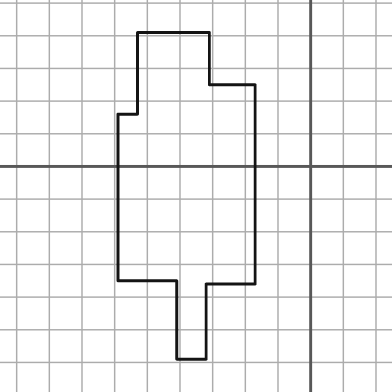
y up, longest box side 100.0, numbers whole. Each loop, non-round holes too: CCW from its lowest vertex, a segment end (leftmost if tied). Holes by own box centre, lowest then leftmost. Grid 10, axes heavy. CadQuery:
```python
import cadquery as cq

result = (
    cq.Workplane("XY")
    .moveTo(-41.0, -59.0)
    .lineTo(-32.0, -59.0)
    .lineTo(-32.0, -36.0)
    .lineTo(-17.0, -36.0)
    .lineTo(-17.0, 25.0)
    .lineTo(-31.0, 25.0)
    .lineTo(-31.0, 41.0)
    .lineTo(-53.0, 41.0)
    .lineTo(-53.0, 16.0)
    .lineTo(-59.0, 16.0)
    .lineTo(-59.0, -35.0)
    .lineTo(-41.0, -35.0)
    .close()
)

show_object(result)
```